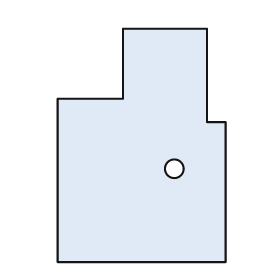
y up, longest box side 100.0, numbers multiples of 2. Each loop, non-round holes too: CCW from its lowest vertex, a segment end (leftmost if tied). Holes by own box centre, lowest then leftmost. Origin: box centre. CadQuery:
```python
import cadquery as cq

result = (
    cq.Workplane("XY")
    .moveTo(-36.0, -50.0)
    .lineTo(36.0, -50.0)
    .lineTo(36.0, 10.0)
    .lineTo(28.0, 10.0)
    .lineTo(28.0, 50.0)
    .lineTo(-8.0, 50.0)
    .lineTo(-8.0, 20.0)
    .lineTo(-36.0, 20.0)
    .close()
    .moveTo(14.0, -10.0)
    .circle(4.0)
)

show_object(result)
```